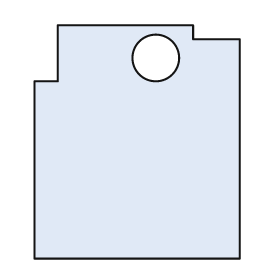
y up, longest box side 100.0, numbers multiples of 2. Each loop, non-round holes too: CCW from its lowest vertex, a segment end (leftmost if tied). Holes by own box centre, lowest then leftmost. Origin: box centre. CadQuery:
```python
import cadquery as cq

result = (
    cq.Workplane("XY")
    .moveTo(-44.0, -50.0)
    .lineTo(44.0, -50.0)
    .lineTo(44.0, 44.0)
    .lineTo(24.0, 44.0)
    .lineTo(24.0, 50.0)
    .lineTo(-34.0, 50.0)
    .lineTo(-34.0, 26.0)
    .lineTo(-44.0, 26.0)
    .close()
    .moveTo(8.0, 36.0)
    .circle(10.0)
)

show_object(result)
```